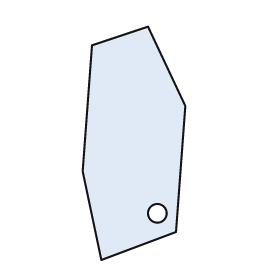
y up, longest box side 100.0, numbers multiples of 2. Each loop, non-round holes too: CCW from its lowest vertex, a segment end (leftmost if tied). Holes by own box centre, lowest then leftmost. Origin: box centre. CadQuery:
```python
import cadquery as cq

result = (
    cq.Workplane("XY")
    .moveTo(-14.0, -50.0)
    .lineTo(18.0, -38.0)
    .lineTo(22.0, 16.0)
    .lineTo(6.0, 50.0)
    .lineTo(-18.0, 42.0)
    .lineTo(-22.0, -12.0)
    .close()
    .moveTo(10.0, -30.0)
    .circle(4.0)
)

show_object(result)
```